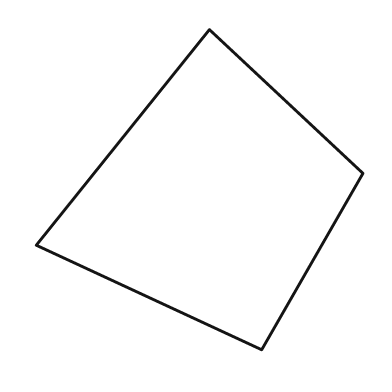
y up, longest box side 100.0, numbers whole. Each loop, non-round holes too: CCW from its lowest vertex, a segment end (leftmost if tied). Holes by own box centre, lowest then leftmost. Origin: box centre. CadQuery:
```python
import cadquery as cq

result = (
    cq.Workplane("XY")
    .moveTo(19.0, -49.0)
    .lineTo(50.0, 5.0)
    .lineTo(3.0, 49.0)
    .lineTo(-50.0, -17.0)
    .close()
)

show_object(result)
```